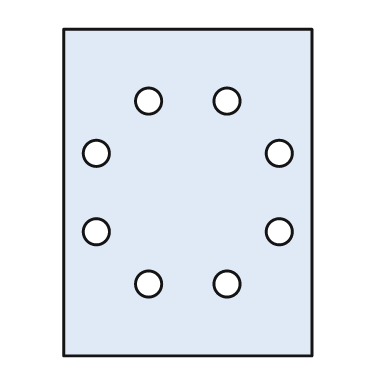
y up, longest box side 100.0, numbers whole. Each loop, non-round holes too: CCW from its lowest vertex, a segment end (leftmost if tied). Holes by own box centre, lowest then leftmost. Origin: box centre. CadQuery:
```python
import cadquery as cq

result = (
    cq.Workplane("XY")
    .moveTo(-38.0, -50.0)
    .lineTo(38.0, -50.0)
    .lineTo(38.0, 50.0)
    .lineTo(-38.0, 50.0)
    .close()
    .moveTo(-12.0, -28.0)
    .circle(4.0)
    .moveTo(12.0, -28.0)
    .circle(4.0)
    .moveTo(-28.0, -12.0)
    .circle(4.0)
    .moveTo(28.0, -12.0)
    .circle(4.0)
    .moveTo(-28.0, 12.0)
    .circle(4.0)
    .moveTo(28.0, 12.0)
    .circle(4.0)
    .moveTo(-12.0, 28.0)
    .circle(4.0)
    .moveTo(12.0, 28.0)
    .circle(4.0)
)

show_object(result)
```